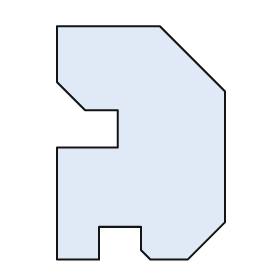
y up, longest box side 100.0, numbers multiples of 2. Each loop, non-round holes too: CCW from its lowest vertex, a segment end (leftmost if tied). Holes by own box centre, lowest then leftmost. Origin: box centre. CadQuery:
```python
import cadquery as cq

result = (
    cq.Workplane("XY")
    .moveTo(-36.0, -50.0)
    .lineTo(-18.0, -50.0)
    .lineTo(-18.0, -36.0)
    .lineTo(0.0, -36.0)
    .lineTo(0.0, -46.0)
    .lineTo(4.0, -50.0)
    .lineTo(20.0, -50.0)
    .lineTo(36.0, -34.0)
    .lineTo(36.0, 22.0)
    .lineTo(8.0, 50.0)
    .lineTo(-36.0, 50.0)
    .lineTo(-36.0, 26.0)
    .lineTo(-24.0, 14.0)
    .lineTo(-10.0, 14.0)
    .lineTo(-10.0, -2.0)
    .lineTo(-36.0, -2.0)
    .close()
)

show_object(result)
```